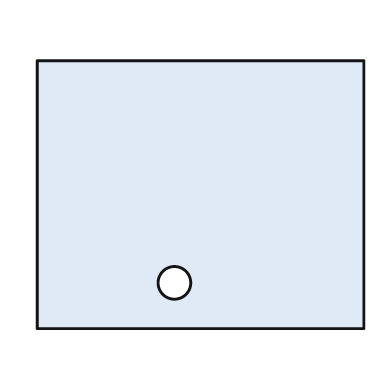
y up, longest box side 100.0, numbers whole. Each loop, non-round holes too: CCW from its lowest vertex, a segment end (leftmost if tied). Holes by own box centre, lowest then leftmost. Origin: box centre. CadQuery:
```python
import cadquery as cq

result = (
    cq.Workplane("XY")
    .moveTo(-50.0, -41.0)
    .lineTo(50.0, -41.0)
    .lineTo(50.0, 41.0)
    .lineTo(-50.0, 41.0)
    .close()
    .moveTo(-8.0, -27.0)
    .circle(5.0)
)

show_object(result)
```